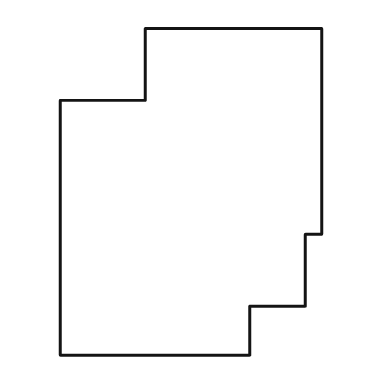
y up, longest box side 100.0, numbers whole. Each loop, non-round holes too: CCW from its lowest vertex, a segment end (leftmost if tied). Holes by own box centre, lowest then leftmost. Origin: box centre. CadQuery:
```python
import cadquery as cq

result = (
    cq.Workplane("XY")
    .moveTo(-40.0, -50.0)
    .lineTo(18.0, -50.0)
    .lineTo(18.0, -35.0)
    .lineTo(35.0, -35.0)
    .lineTo(35.0, -13.0)
    .lineTo(40.0, -13.0)
    .lineTo(40.0, 50.0)
    .lineTo(-14.0, 50.0)
    .lineTo(-14.0, 28.0)
    .lineTo(-40.0, 28.0)
    .close()
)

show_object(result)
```